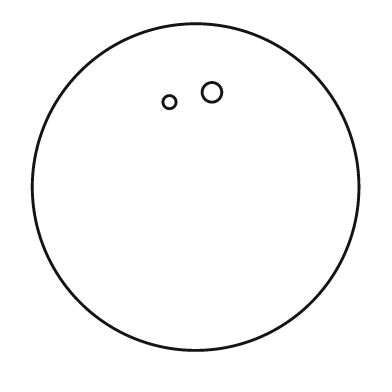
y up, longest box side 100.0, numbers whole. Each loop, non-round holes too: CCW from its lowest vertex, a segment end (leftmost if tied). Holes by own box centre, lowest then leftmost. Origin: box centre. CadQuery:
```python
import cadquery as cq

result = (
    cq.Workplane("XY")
    .moveTo(0.0, 0.0)
    .circle(50.0)
    .moveTo(-8.0, 26.0)
    .circle(2.0)
    .moveTo(5.0, 29.0)
    .circle(3.0)
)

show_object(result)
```